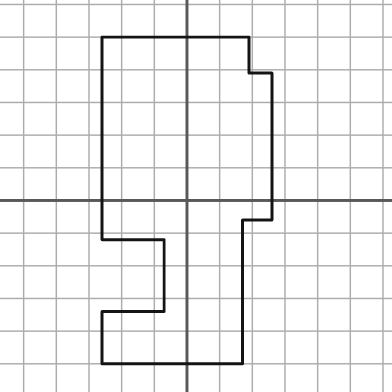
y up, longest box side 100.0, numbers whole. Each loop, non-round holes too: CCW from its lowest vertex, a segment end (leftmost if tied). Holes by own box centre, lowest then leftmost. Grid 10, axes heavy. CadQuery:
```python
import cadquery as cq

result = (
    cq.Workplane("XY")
    .moveTo(-26.0, -50.0)
    .lineTo(17.0, -50.0)
    .lineTo(17.0, -6.0)
    .lineTo(26.0, -6.0)
    .lineTo(26.0, 39.0)
    .lineTo(19.0, 39.0)
    .lineTo(19.0, 50.0)
    .lineTo(-26.0, 50.0)
    .lineTo(-26.0, -12.0)
    .lineTo(-7.0, -12.0)
    .lineTo(-7.0, -34.0)
    .lineTo(-26.0, -34.0)
    .close()
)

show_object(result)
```